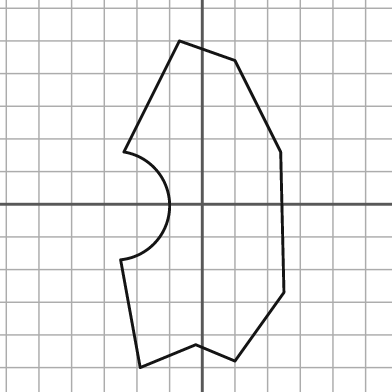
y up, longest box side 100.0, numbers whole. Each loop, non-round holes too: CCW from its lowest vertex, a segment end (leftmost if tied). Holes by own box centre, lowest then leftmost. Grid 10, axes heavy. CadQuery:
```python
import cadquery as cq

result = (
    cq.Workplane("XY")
    .moveTo(-19.0, -50.0)
    .lineTo(-2.0, -43.0)
    .lineTo(10.0, -48.0)
    .lineTo(25.0, -27.0)
    .lineTo(24.0, 16.0)
    .lineTo(10.0, 44.0)
    .lineTo(-7.0, 50.0)
    .lineTo(-24.0, 16.0)
    .threePointArc((-10.0, -1.0), (-25.0, -17.0))
    .close()
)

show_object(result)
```